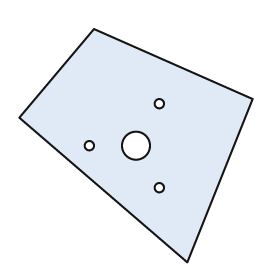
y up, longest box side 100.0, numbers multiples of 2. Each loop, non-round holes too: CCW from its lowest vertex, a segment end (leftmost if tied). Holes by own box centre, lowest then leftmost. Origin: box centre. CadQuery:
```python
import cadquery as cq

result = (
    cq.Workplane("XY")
    .moveTo(22.0, -50.0)
    .lineTo(50.0, 20.0)
    .lineTo(-18.0, 50.0)
    .lineTo(-50.0, 12.0)
    .close()
    .moveTo(10.0, -18.0)
    .circle(2.0)
    .moveTo(-20.0, 0.0)
    .circle(2.0)
    .moveTo(0.0, 0.0)
    .circle(6.0)
    .moveTo(10.0, 18.0)
    .circle(2.0)
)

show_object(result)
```